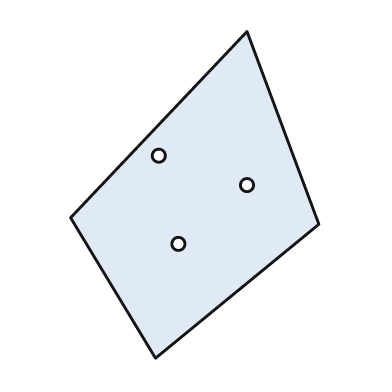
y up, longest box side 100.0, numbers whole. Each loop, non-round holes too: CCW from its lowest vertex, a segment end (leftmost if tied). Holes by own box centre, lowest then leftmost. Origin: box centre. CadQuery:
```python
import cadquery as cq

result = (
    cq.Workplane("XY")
    .moveTo(-12.0, -50.0)
    .lineTo(38.0, -9.0)
    .lineTo(16.0, 50.0)
    .lineTo(-38.0, -7.0)
    .close()
    .moveTo(-5.0, -15.0)
    .circle(2.0)
    .moveTo(16.0, 3.0)
    .circle(2.0)
    .moveTo(-11.0, 12.0)
    .circle(2.0)
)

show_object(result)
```